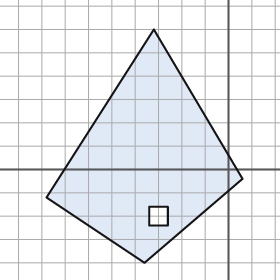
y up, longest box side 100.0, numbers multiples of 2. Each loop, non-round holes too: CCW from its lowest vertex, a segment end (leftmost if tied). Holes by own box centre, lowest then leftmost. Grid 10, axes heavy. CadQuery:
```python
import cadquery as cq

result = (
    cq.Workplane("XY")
    .moveTo(-36.0, -40.0)
    .lineTo(6.0, -4.0)
    .lineTo(-32.0, 60.0)
    .lineTo(-78.0, -12.0)
    .close()
    .moveTo(-34.0, -24.0)
    .lineTo(-26.0, -24.0)
    .lineTo(-26.0, -16.0)
    .lineTo(-34.0, -16.0)
    .close()
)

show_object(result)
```